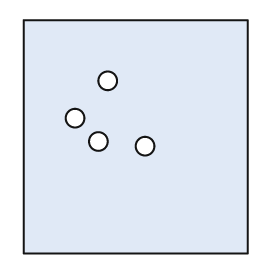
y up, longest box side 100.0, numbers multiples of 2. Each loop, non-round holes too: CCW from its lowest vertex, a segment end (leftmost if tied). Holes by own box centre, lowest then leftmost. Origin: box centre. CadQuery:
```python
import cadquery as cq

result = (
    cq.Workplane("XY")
    .moveTo(-48.0, -50.0)
    .lineTo(48.0, -50.0)
    .lineTo(48.0, 50.0)
    .lineTo(-48.0, 50.0)
    .close()
    .moveTo(4.0, -4.0)
    .circle(4.0)
    .moveTo(-16.0, -2.0)
    .circle(4.0)
    .moveTo(-26.0, 8.0)
    .circle(4.0)
    .moveTo(-12.0, 24.0)
    .circle(4.0)
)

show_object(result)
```